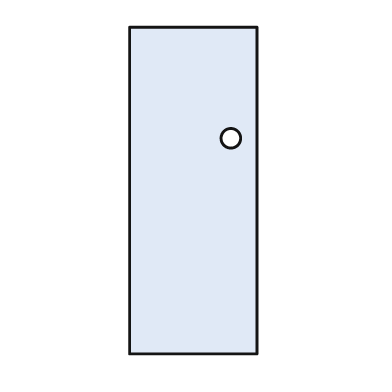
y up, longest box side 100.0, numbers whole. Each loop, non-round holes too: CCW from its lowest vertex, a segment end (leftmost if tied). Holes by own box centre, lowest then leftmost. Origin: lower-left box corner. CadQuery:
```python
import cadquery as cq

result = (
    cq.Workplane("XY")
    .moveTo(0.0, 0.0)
    .lineTo(39.0, 0.0)
    .lineTo(39.0, 100.0)
    .lineTo(0.0, 100.0)
    .close()
    .moveTo(31.0, 66.0)
    .circle(3.0)
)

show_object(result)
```